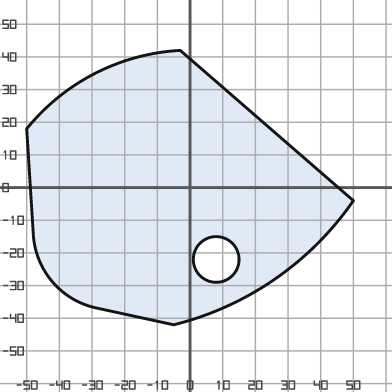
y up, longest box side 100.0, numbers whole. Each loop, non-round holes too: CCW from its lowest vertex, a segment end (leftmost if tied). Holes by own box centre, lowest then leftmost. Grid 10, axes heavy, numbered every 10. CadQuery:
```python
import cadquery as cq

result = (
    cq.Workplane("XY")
    .moveTo(-5.0, -42.0)
    .threePointArc((26.0, -28.0), (50.0, -4.0))
    .lineTo(-3.0, 42.0)
    .threePointArc((-29.0, 35.0), (-50.0, 18.0))
    .lineTo(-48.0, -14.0)
    .threePointArc((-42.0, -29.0), (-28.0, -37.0))
    .close()
    .moveTo(8.0, -22.0)
    .circle(7.0)
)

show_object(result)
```